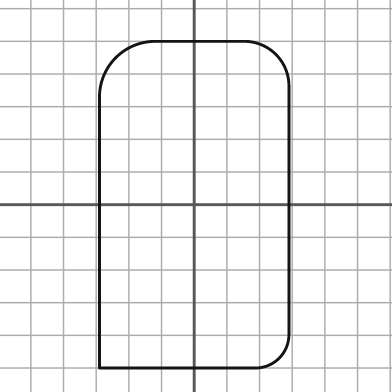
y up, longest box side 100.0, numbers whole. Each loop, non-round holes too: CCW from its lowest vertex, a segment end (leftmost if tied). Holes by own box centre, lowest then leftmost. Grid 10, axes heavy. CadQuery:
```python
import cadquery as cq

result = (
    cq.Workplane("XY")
    .moveTo(-29.0, -50.0)
    .lineTo(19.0, -50.0)
    .threePointArc((26.0, -47.0), (29.0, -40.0))
    .lineTo(29.0, 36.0)
    .threePointArc((25.0, 46.0), (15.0, 50.0))
    .lineTo(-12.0, 50.0)
    .threePointArc((-24.0, 45.0), (-29.0, 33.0))
    .close()
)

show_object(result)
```